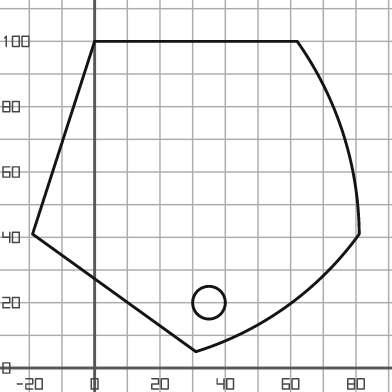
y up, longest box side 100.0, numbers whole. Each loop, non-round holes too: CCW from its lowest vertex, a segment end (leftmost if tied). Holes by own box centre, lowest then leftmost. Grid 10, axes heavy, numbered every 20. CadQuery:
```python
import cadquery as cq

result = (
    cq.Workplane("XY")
    .moveTo(31.0, 5.0)
    .threePointArc((59.0, 19.0), (81.0, 41.0))
    .threePointArc((76.0, 72.0), (62.0, 100.0))
    .lineTo(0.0, 100.0)
    .lineTo(-19.0, 41.0)
    .close()
    .moveTo(35.0, 20.0)
    .circle(5.0)
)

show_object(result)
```